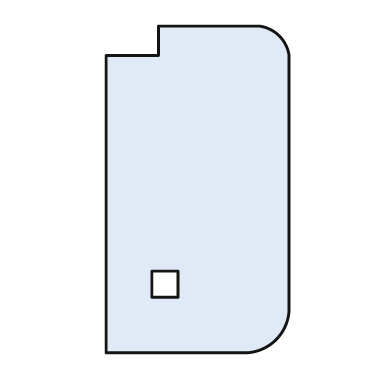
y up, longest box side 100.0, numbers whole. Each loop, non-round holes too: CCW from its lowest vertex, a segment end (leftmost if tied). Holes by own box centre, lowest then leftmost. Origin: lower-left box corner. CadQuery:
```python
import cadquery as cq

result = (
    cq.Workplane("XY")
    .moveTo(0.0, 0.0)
    .lineTo(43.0, 0.0)
    .threePointArc((52.0, 4.0), (56.0, 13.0))
    .lineTo(56.0, 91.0)
    .threePointArc((53.0, 97.0), (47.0, 100.0))
    .lineTo(16.0, 100.0)
    .lineTo(16.0, 91.0)
    .lineTo(0.0, 91.0)
    .close()
    .moveTo(14.0, 17.0)
    .lineTo(22.0, 17.0)
    .lineTo(22.0, 25.0)
    .lineTo(14.0, 25.0)
    .close()
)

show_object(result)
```